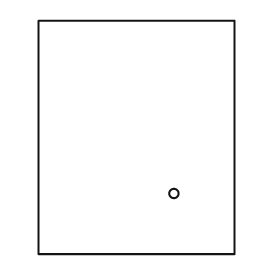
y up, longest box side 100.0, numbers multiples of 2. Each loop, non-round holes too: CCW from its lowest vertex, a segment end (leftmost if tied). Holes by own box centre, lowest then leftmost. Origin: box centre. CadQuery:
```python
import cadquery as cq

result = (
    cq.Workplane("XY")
    .moveTo(-42.0, -50.0)
    .lineTo(42.0, -50.0)
    .lineTo(42.0, 50.0)
    .lineTo(-42.0, 50.0)
    .close()
    .moveTo(16.0, -24.0)
    .circle(2.0)
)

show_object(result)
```